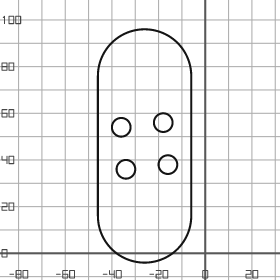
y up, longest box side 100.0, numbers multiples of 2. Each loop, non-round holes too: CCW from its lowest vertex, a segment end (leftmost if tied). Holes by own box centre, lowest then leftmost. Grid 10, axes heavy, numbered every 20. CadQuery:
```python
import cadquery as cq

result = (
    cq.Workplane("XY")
    .moveTo(-46.0, 16.0)
    .threePointArc((-26.0, -4.0), (-6.0, 16.0))
    .lineTo(-6.0, 76.0)
    .threePointArc((-26.0, 96.0), (-46.0, 76.0))
    .close()
    .moveTo(-34.0, 36.0)
    .circle(4.0)
    .moveTo(-16.0, 38.0)
    .circle(4.0)
    .moveTo(-36.0, 54.0)
    .circle(4.0)
    .moveTo(-18.0, 56.0)
    .circle(4.0)
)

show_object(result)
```